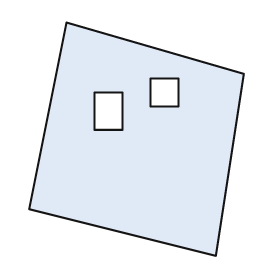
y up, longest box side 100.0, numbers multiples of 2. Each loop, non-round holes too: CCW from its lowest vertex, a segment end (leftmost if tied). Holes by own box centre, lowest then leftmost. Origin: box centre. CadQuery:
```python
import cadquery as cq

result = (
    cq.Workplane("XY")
    .moveTo(34.0, -50.0)
    .lineTo(46.0, 28.0)
    .lineTo(-30.0, 50.0)
    .lineTo(-46.0, -30.0)
    .close()
    .moveTo(-18.0, 4.0)
    .lineTo(-6.0, 4.0)
    .lineTo(-6.0, 20.0)
    .lineTo(-18.0, 20.0)
    .close()
    .moveTo(6.0, 14.0)
    .lineTo(18.0, 14.0)
    .lineTo(18.0, 26.0)
    .lineTo(6.0, 26.0)
    .close()
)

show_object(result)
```